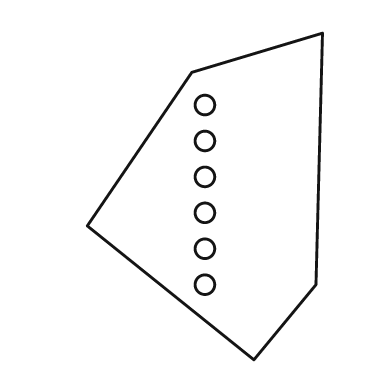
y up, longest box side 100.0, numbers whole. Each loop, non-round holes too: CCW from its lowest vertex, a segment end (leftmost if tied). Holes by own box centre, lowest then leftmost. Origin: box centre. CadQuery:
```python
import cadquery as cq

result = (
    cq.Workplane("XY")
    .moveTo(15.0, -50.0)
    .lineTo(34.0, -27.0)
    .lineTo(36.0, 50.0)
    .lineTo(-4.0, 38.0)
    .lineTo(-36.0, -9.0)
    .close()
    .moveTo(0.0, -27.0)
    .circle(3.0)
    .moveTo(0.0, -16.0)
    .circle(3.0)
    .moveTo(0.0, -5.0)
    .circle(3.0)
    .moveTo(0.0, 6.0)
    .circle(3.0)
    .moveTo(0.0, 17.0)
    .circle(3.0)
    .moveTo(0.0, 28.0)
    .circle(3.0)
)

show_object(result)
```